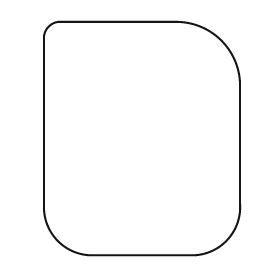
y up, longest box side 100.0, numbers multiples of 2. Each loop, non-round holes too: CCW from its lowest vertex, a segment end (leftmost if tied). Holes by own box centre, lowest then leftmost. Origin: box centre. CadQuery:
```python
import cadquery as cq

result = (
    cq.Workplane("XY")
    .moveTo(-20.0, -50.0)
    .lineTo(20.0, -50.0)
    .threePointArc((36.0, -44.0), (42.0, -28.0))
    .lineTo(42.0, 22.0)
    .threePointArc((34.0, 42.0), (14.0, 50.0))
    .lineTo(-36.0, 50.0)
    .threePointArc((-40.0, 48.0), (-42.0, 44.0))
    .lineTo(-42.0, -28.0)
    .threePointArc((-36.0, -44.0), (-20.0, -50.0))
    .close()
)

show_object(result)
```